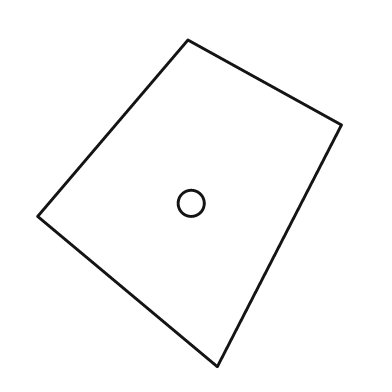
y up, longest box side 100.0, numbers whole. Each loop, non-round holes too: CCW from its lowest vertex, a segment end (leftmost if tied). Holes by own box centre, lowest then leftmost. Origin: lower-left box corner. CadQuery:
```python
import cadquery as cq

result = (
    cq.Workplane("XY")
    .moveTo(55.0, 0.0)
    .lineTo(93.0, 74.0)
    .lineTo(46.0, 100.0)
    .lineTo(0.0, 46.0)
    .close()
    .moveTo(47.0, 50.0)
    .circle(4.0)
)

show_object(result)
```